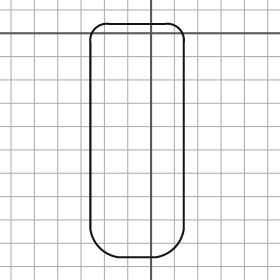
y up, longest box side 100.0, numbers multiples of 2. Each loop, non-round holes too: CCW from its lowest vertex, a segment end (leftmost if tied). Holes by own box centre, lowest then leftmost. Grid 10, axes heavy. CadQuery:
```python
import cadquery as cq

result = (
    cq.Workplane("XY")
    .moveTo(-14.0, -96.0)
    .lineTo(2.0, -96.0)
    .threePointArc((10.0, -92.0), (14.0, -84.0))
    .lineTo(14.0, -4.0)
    .threePointArc((12.0, 2.0), (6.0, 4.0))
    .lineTo(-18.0, 4.0)
    .threePointArc((-24.0, 2.0), (-26.0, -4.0))
    .lineTo(-26.0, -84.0)
    .threePointArc((-22.0, -92.0), (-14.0, -96.0))
    .close()
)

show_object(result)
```